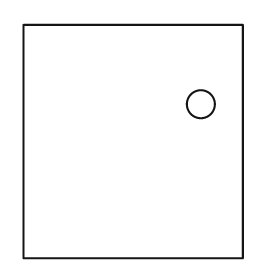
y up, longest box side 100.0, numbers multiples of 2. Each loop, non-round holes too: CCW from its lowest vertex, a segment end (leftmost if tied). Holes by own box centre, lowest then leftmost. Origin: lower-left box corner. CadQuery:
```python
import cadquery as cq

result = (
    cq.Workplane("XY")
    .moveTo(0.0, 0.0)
    .lineTo(94.0, 0.0)
    .lineTo(94.0, 100.0)
    .lineTo(0.0, 100.0)
    .close()
    .moveTo(76.0, 66.0)
    .circle(6.0)
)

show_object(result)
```